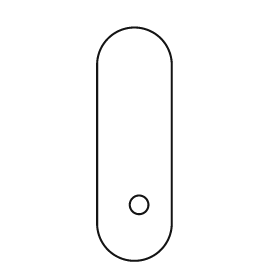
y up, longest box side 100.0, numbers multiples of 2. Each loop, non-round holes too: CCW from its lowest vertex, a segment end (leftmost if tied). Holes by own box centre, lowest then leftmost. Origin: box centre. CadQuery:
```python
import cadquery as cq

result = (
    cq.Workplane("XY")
    .moveTo(-16.0, -34.0)
    .threePointArc((0.0, -50.0), (16.0, -34.0))
    .lineTo(16.0, 34.0)
    .threePointArc((0.0, 50.0), (-16.0, 34.0))
    .close()
    .moveTo(2.0, -26.0)
    .circle(4.0)
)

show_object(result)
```